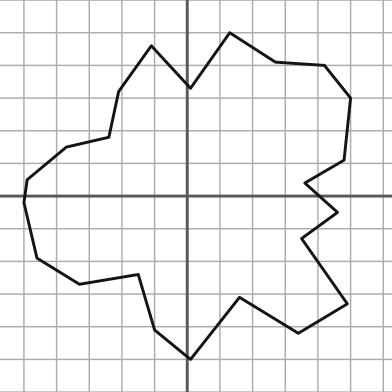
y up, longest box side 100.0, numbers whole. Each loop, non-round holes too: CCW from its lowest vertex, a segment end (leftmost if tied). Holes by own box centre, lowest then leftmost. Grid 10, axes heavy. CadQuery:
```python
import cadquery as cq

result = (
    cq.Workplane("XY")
    .moveTo(1.0, -50.0)
    .lineTo(16.0, -31.0)
    .lineTo(34.0, -42.0)
    .lineTo(49.0, -33.0)
    .lineTo(35.0, -13.0)
    .lineTo(46.0, -5.0)
    .lineTo(36.0, 4.0)
    .lineTo(48.0, 11.0)
    .lineTo(50.0, 30.0)
    .lineTo(42.0, 40.0)
    .lineTo(27.0, 41.0)
    .lineTo(13.0, 50.0)
    .lineTo(1.0, 33.0)
    .lineTo(-11.0, 46.0)
    .lineTo(-21.0, 32.0)
    .lineTo(-24.0, 18.0)
    .lineTo(-37.0, 15.0)
    .lineTo(-49.0, 5.0)
    .lineTo(-50.0, -2.0)
    .lineTo(-46.0, -19.0)
    .lineTo(-33.0, -27.0)
    .lineTo(-15.0, -24.0)
    .lineTo(-10.0, -41.0)
    .close()
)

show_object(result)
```